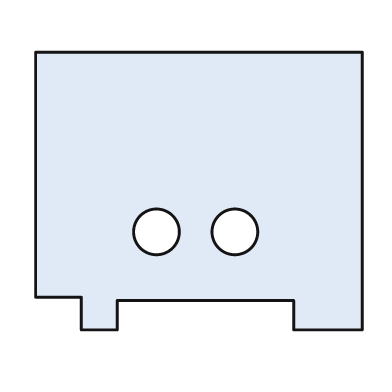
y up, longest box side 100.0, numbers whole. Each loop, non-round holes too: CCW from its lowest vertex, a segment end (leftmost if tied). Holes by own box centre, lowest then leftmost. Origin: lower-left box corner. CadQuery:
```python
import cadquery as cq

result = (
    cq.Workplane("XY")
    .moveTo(14.0, 0.0)
    .lineTo(25.0, 0.0)
    .lineTo(25.0, 9.0)
    .lineTo(79.0, 9.0)
    .lineTo(79.0, 0.0)
    .lineTo(100.0, 0.0)
    .lineTo(100.0, 85.0)
    .lineTo(0.0, 85.0)
    .lineTo(0.0, 10.0)
    .lineTo(14.0, 10.0)
    .close()
    .moveTo(37.0, 30.0)
    .circle(7.0)
    .moveTo(61.0, 30.0)
    .circle(7.0)
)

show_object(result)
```